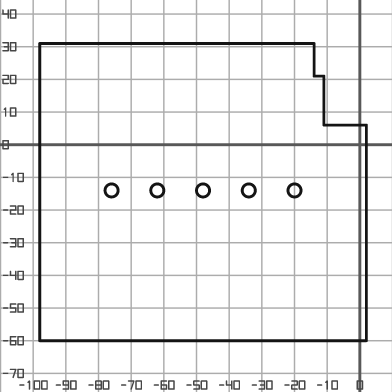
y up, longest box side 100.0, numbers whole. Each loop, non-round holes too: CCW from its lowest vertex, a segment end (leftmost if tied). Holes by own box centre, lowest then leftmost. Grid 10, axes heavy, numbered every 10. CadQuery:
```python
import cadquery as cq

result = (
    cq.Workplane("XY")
    .moveTo(-98.0, -60.0)
    .lineTo(2.0, -60.0)
    .lineTo(2.0, 6.0)
    .lineTo(-11.0, 6.0)
    .lineTo(-11.0, 21.0)
    .lineTo(-14.0, 21.0)
    .lineTo(-14.0, 31.0)
    .lineTo(-98.0, 31.0)
    .close()
    .moveTo(-76.0, -14.0)
    .circle(2.0)
    .moveTo(-62.0, -14.0)
    .circle(2.0)
    .moveTo(-48.0, -14.0)
    .circle(2.0)
    .moveTo(-34.0, -14.0)
    .circle(2.0)
    .moveTo(-20.0, -14.0)
    .circle(2.0)
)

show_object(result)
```